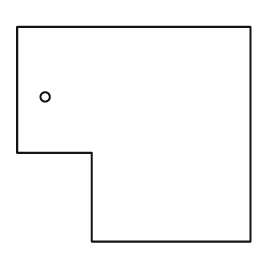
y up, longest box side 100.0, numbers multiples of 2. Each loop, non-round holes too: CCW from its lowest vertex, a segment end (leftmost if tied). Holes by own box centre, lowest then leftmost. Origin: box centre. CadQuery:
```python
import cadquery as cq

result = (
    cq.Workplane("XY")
    .moveTo(-18.0, -46.0)
    .lineTo(50.0, -46.0)
    .lineTo(50.0, 46.0)
    .lineTo(-50.0, 46.0)
    .lineTo(-50.0, -8.0)
    .lineTo(-18.0, -8.0)
    .close()
    .moveTo(-38.0, 16.0)
    .circle(2.0)
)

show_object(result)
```